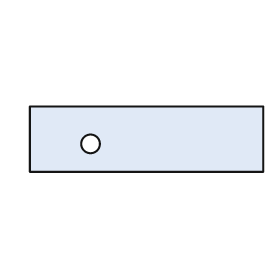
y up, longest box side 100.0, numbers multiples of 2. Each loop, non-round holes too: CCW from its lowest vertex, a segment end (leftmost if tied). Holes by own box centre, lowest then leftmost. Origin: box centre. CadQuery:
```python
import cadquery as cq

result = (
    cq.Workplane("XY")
    .moveTo(-50.0, -14.0)
    .lineTo(50.0, -14.0)
    .lineTo(50.0, 14.0)
    .lineTo(-50.0, 14.0)
    .close()
    .moveTo(-24.0, -2.0)
    .circle(4.0)
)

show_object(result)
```